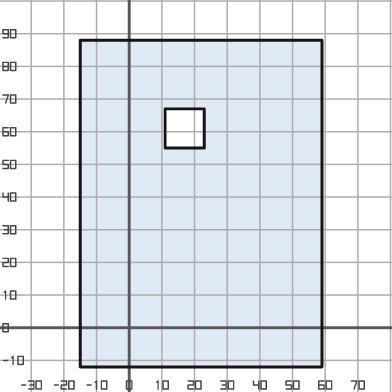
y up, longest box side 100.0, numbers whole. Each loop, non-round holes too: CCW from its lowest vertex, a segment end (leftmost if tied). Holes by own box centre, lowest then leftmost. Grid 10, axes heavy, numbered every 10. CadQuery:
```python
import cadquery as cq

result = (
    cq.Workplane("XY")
    .moveTo(-15.0, -12.0)
    .lineTo(59.0, -12.0)
    .lineTo(59.0, 88.0)
    .lineTo(-15.0, 88.0)
    .close()
    .moveTo(11.0, 55.0)
    .lineTo(23.0, 55.0)
    .lineTo(23.0, 67.0)
    .lineTo(11.0, 67.0)
    .close()
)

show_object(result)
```